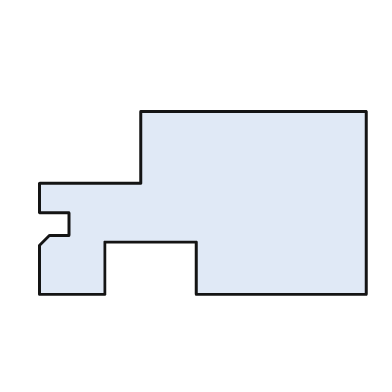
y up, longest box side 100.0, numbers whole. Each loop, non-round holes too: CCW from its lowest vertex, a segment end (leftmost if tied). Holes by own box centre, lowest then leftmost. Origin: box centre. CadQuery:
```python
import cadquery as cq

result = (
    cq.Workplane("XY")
    .moveTo(-50.0, -28.0)
    .lineTo(-30.0, -28.0)
    .lineTo(-30.0, -12.0)
    .lineTo(-2.0, -12.0)
    .lineTo(-2.0, -28.0)
    .lineTo(50.0, -28.0)
    .lineTo(50.0, 28.0)
    .lineTo(-19.0, 28.0)
    .lineTo(-19.0, 6.0)
    .lineTo(-50.0, 6.0)
    .lineTo(-50.0, -3.0)
    .lineTo(-41.0, -3.0)
    .lineTo(-41.0, -10.0)
    .lineTo(-47.0, -10.0)
    .lineTo(-50.0, -13.0)
    .close()
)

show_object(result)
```